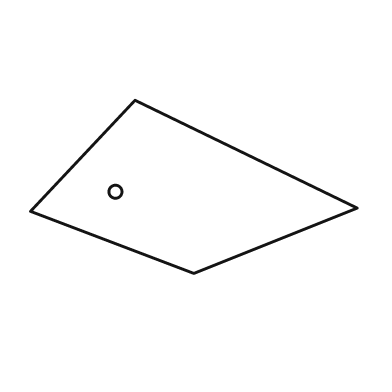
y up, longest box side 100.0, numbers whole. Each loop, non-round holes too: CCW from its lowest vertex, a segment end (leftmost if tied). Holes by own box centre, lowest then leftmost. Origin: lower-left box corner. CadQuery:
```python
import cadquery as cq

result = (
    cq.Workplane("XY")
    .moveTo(50.0, 0.0)
    .lineTo(100.0, 20.0)
    .lineTo(32.0, 53.0)
    .lineTo(0.0, 19.0)
    .close()
    .moveTo(26.0, 25.0)
    .circle(2.0)
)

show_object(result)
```